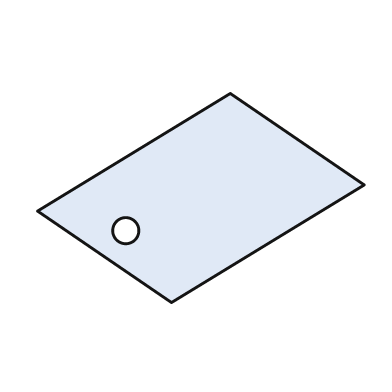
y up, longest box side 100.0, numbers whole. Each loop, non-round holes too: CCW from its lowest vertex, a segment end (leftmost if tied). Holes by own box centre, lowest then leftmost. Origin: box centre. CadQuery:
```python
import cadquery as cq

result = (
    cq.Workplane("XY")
    .moveTo(-9.0, -32.0)
    .lineTo(50.0, 4.0)
    .lineTo(9.0, 32.0)
    .lineTo(-50.0, -4.0)
    .close()
    .moveTo(-23.0, -10.0)
    .circle(4.0)
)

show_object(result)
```